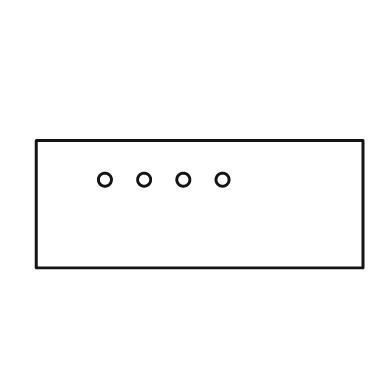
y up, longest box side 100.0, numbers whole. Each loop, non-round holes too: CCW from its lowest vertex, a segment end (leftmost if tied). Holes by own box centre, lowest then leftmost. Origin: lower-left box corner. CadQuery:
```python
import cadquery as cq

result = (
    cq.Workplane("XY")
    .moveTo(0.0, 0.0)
    .lineTo(100.0, 0.0)
    .lineTo(100.0, 39.0)
    .lineTo(0.0, 39.0)
    .close()
    .moveTo(21.0, 27.0)
    .circle(2.0)
    .moveTo(33.0, 27.0)
    .circle(2.0)
    .moveTo(45.0, 27.0)
    .circle(2.0)
    .moveTo(57.0, 27.0)
    .circle(2.0)
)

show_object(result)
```